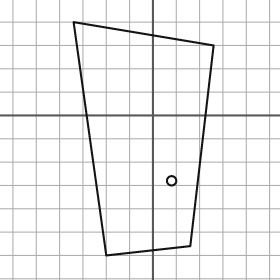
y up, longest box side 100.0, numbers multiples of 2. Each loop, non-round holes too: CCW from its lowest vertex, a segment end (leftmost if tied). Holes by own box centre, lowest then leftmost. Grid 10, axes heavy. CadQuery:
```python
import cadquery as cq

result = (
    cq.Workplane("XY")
    .moveTo(-20.0, -60.0)
    .lineTo(16.0, -56.0)
    .lineTo(26.0, 30.0)
    .lineTo(-34.0, 40.0)
    .close()
    .moveTo(8.0, -28.0)
    .circle(2.0)
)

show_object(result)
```